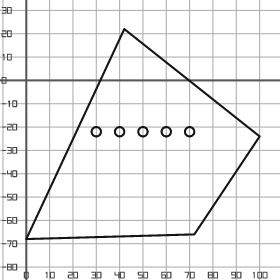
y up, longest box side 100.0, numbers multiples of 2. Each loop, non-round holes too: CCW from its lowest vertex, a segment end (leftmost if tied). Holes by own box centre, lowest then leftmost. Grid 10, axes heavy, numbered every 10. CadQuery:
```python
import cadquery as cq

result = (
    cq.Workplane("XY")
    .moveTo(0.0, -68.0)
    .lineTo(72.0, -66.0)
    .lineTo(100.0, -24.0)
    .lineTo(42.0, 22.0)
    .close()
    .moveTo(30.0, -22.0)
    .circle(2.0)
    .moveTo(40.0, -22.0)
    .circle(2.0)
    .moveTo(50.0, -22.0)
    .circle(2.0)
    .moveTo(60.0, -22.0)
    .circle(2.0)
    .moveTo(70.0, -22.0)
    .circle(2.0)
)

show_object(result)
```